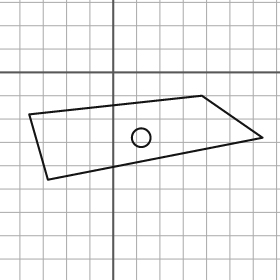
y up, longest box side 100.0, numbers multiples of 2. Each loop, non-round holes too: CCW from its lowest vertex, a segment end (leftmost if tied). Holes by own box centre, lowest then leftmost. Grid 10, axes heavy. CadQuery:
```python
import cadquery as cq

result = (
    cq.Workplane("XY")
    .moveTo(-28.0, -46.0)
    .lineTo(64.0, -28.0)
    .lineTo(38.0, -10.0)
    .lineTo(-36.0, -18.0)
    .close()
    .moveTo(12.0, -28.0)
    .circle(4.0)
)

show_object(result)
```